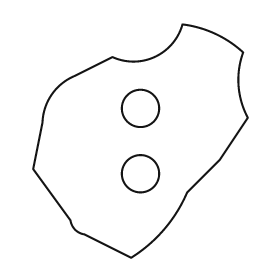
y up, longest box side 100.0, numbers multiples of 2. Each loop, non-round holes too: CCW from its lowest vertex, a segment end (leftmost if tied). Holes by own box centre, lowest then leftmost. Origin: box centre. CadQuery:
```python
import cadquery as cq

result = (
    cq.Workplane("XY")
    .moveTo(-4.0, -50.0)
    .threePointArc((10.0, -38.0), (20.0, -22.0))
    .lineTo(34.0, -8.0)
    .lineTo(46.0, 10.0)
    .threePointArc((42.0, 24.0), (44.0, 38.0))
    .threePointArc((32.0, 46.0), (18.0, 50.0))
    .threePointArc((6.0, 36.0), (-12.0, 36.0))
    .lineTo(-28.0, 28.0)
    .threePointArc((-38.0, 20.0), (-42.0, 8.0))
    .lineTo(-46.0, -12.0)
    .lineTo(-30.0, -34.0)
    .threePointArc((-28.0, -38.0), (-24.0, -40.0))
    .close()
    .moveTo(0.0, -14.0)
    .circle(8.0)
    .moveTo(0.0, 14.0)
    .circle(8.0)
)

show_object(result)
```